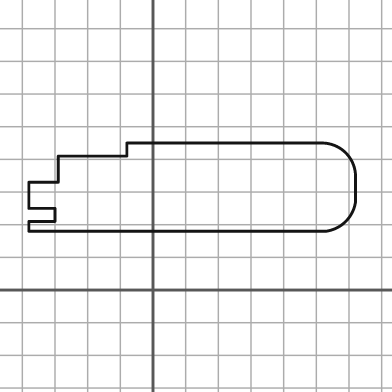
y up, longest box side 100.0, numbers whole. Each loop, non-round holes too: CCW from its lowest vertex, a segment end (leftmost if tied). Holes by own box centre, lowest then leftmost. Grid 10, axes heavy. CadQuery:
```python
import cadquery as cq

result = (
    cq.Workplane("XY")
    .moveTo(-38.0, 18.0)
    .lineTo(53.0, 18.0)
    .threePointArc((59.0, 21.0), (62.0, 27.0))
    .lineTo(62.0, 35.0)
    .threePointArc((59.0, 42.0), (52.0, 45.0))
    .lineTo(-8.0, 45.0)
    .lineTo(-8.0, 41.0)
    .lineTo(-29.0, 41.0)
    .lineTo(-29.0, 33.0)
    .lineTo(-38.0, 33.0)
    .lineTo(-38.0, 25.0)
    .lineTo(-30.0, 25.0)
    .lineTo(-30.0, 21.0)
    .lineTo(-38.0, 21.0)
    .close()
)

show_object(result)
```